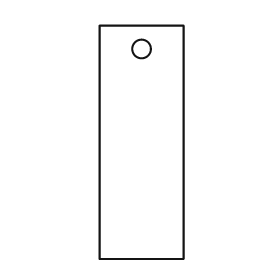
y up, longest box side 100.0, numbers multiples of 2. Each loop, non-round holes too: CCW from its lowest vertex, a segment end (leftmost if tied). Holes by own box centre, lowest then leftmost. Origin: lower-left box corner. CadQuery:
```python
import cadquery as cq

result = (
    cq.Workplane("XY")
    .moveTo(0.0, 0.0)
    .lineTo(36.0, 0.0)
    .lineTo(36.0, 100.0)
    .lineTo(0.0, 100.0)
    .close()
    .moveTo(18.0, 90.0)
    .circle(4.0)
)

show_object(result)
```